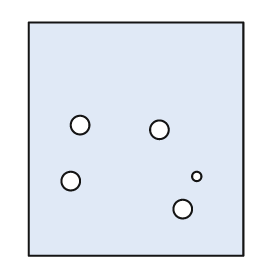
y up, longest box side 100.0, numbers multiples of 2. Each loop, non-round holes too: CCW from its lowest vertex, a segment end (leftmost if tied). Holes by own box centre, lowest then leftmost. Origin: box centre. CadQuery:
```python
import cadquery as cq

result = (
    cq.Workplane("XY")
    .moveTo(-46.0, -50.0)
    .lineTo(46.0, -50.0)
    .lineTo(46.0, 50.0)
    .lineTo(-46.0, 50.0)
    .close()
    .moveTo(20.0, -30.0)
    .circle(4.0)
    .moveTo(-28.0, -18.0)
    .circle(4.0)
    .moveTo(26.0, -16.0)
    .circle(2.0)
    .moveTo(10.0, 4.0)
    .circle(4.0)
    .moveTo(-24.0, 6.0)
    .circle(4.0)
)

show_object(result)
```